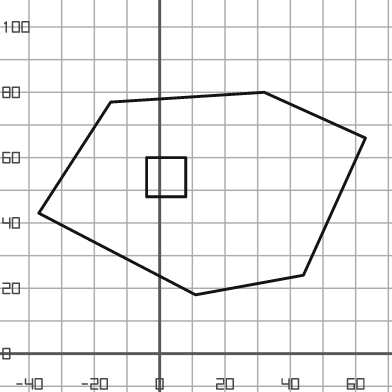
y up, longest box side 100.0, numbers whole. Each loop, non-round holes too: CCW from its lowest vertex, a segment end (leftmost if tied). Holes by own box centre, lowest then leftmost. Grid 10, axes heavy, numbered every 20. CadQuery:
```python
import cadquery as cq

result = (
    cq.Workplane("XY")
    .moveTo(11.0, 18.0)
    .lineTo(44.0, 24.0)
    .lineTo(63.0, 66.0)
    .lineTo(32.0, 80.0)
    .lineTo(-15.0, 77.0)
    .lineTo(-37.0, 43.0)
    .close()
    .moveTo(-4.0, 48.0)
    .lineTo(8.0, 48.0)
    .lineTo(8.0, 60.0)
    .lineTo(-4.0, 60.0)
    .close()
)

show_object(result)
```